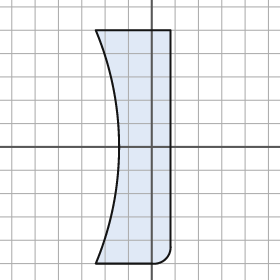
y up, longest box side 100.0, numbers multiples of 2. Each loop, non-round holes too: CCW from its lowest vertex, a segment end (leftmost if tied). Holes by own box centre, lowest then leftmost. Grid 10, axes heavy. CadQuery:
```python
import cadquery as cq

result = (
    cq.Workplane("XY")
    .moveTo(-24.0, -50.0)
    .lineTo(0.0, -50.0)
    .threePointArc((6.0, -48.0), (8.0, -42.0))
    .lineTo(8.0, 50.0)
    .lineTo(-24.0, 50.0)
    .threePointArc((-14.0, 0.0), (-24.0, -50.0))
    .close()
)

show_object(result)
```